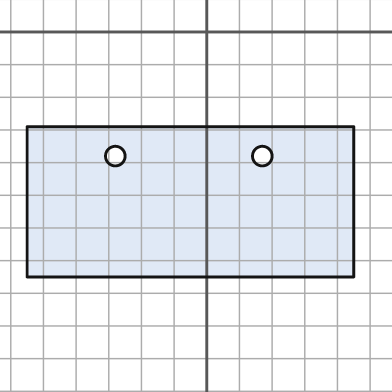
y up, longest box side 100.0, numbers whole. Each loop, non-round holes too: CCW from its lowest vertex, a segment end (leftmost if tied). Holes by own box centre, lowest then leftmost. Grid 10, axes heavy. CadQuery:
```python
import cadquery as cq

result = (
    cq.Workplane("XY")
    .moveTo(-55.0, -75.0)
    .lineTo(45.0, -75.0)
    .lineTo(45.0, -29.0)
    .lineTo(-55.0, -29.0)
    .close()
    .moveTo(-28.0, -38.0)
    .circle(3.0)
    .moveTo(17.0, -38.0)
    .circle(3.0)
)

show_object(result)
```